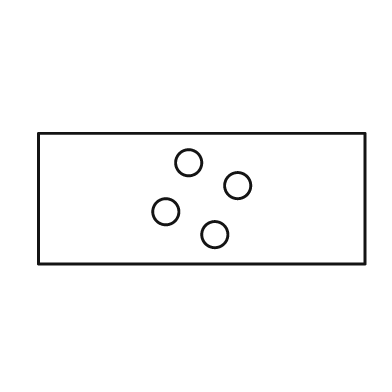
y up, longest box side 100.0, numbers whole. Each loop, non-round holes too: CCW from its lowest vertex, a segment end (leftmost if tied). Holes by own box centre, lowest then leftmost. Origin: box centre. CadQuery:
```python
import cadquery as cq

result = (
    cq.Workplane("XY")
    .moveTo(-50.0, -20.0)
    .lineTo(50.0, -20.0)
    .lineTo(50.0, 20.0)
    .lineTo(-50.0, 20.0)
    .close()
    .moveTo(4.0, -11.0)
    .circle(4.0)
    .moveTo(-11.0, -4.0)
    .circle(4.0)
    .moveTo(11.0, 4.0)
    .circle(4.0)
    .moveTo(-4.0, 11.0)
    .circle(4.0)
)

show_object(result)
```